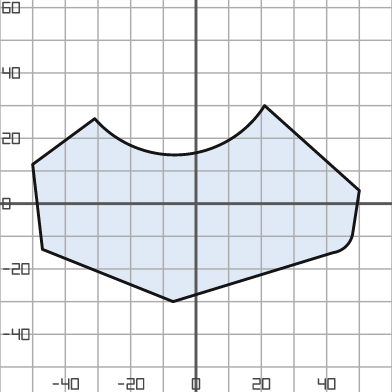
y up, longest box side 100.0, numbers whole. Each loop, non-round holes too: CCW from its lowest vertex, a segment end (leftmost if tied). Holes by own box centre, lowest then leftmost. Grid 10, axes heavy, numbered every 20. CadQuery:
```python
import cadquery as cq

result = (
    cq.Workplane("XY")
    .moveTo(-7.0, -30.0)
    .lineTo(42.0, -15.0)
    .threePointArc((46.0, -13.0), (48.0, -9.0))
    .lineTo(50.0, 4.0)
    .lineTo(21.0, 30.0)
    .threePointArc((-4.0, 15.0), (-31.0, 26.0))
    .lineTo(-50.0, 12.0)
    .lineTo(-47.0, -14.0)
    .close()
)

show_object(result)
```